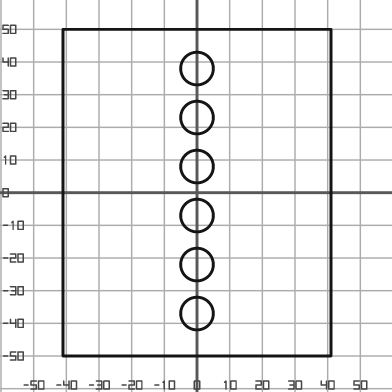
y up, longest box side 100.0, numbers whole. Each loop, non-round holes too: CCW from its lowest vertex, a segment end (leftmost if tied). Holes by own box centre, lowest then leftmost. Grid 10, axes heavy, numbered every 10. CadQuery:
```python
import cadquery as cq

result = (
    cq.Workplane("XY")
    .moveTo(-41.0, -50.0)
    .lineTo(41.0, -50.0)
    .lineTo(41.0, 50.0)
    .lineTo(-41.0, 50.0)
    .close()
    .moveTo(0.0, -37.0)
    .circle(5.0)
    .moveTo(0.0, -22.0)
    .circle(5.0)
    .moveTo(0.0, -7.0)
    .circle(5.0)
    .moveTo(0.0, 8.0)
    .circle(5.0)
    .moveTo(0.0, 23.0)
    .circle(5.0)
    .moveTo(0.0, 38.0)
    .circle(5.0)
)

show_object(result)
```